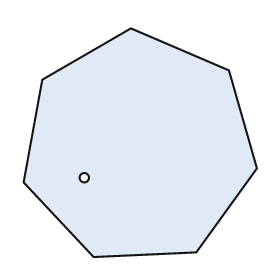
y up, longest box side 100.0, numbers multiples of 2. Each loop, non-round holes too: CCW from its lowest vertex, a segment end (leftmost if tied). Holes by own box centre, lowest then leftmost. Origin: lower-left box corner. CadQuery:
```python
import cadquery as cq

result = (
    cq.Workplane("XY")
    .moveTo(30.0, 0.0)
    .lineTo(74.0, 2.0)
    .lineTo(100.0, 38.0)
    .lineTo(88.0, 80.0)
    .lineTo(46.0, 98.0)
    .lineTo(8.0, 76.0)
    .lineTo(0.0, 32.0)
    .close()
    .moveTo(26.0, 34.0)
    .circle(2.0)
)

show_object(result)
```